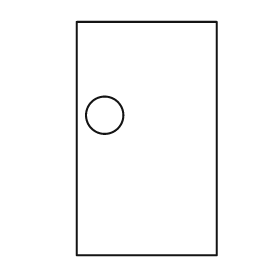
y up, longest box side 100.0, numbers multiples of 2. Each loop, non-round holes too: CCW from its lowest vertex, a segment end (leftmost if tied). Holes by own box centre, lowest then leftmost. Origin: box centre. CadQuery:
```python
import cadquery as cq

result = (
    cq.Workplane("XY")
    .moveTo(-30.0, -50.0)
    .lineTo(30.0, -50.0)
    .lineTo(30.0, 50.0)
    .lineTo(-30.0, 50.0)
    .close()
    .moveTo(-18.0, 10.0)
    .circle(8.0)
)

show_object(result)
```